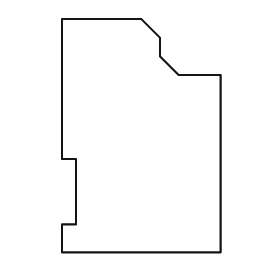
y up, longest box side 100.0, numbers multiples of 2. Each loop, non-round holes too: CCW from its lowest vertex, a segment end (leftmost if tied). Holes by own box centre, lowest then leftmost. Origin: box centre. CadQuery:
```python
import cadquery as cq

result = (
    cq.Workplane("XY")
    .moveTo(-34.0, -50.0)
    .lineTo(34.0, -50.0)
    .lineTo(34.0, 26.0)
    .lineTo(16.0, 26.0)
    .lineTo(8.0, 34.0)
    .lineTo(8.0, 42.0)
    .lineTo(0.0, 50.0)
    .lineTo(-34.0, 50.0)
    .lineTo(-34.0, -10.0)
    .lineTo(-28.0, -10.0)
    .lineTo(-28.0, -38.0)
    .lineTo(-34.0, -38.0)
    .close()
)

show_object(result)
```